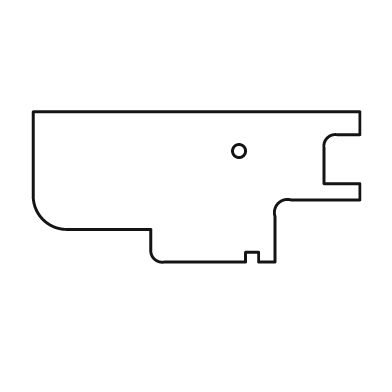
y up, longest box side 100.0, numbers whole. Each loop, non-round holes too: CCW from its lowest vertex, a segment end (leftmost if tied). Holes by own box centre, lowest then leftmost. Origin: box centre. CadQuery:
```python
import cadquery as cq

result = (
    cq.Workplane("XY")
    .moveTo(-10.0, -23.0)
    .lineTo(15.0, -23.0)
    .lineTo(15.0, -20.0)
    .lineTo(19.0, -20.0)
    .lineTo(19.0, -23.0)
    .lineTo(24.0, -23.0)
    .lineTo(24.0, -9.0)
    .threePointArc((25.0, -5.0), (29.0, -4.0))
    .lineTo(50.0, -4.0)
    .lineTo(50.0, 1.0)
    .lineTo(39.0, 1.0)
    .lineTo(39.0, 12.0)
    .threePointArc((40.0, 15.0), (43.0, 16.0))
    .lineTo(50.0, 16.0)
    .lineTo(50.0, 23.0)
    .lineTo(-50.0, 23.0)
    .lineTo(-50.0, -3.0)
    .threePointArc((-47.0, -10.0), (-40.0, -13.0))
    .lineTo(-14.0, -13.0)
    .lineTo(-14.0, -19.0)
    .threePointArc((-13.0, -22.0), (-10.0, -23.0))
    .close()
    .moveTo(13.0, 11.0)
    .circle(2.0)
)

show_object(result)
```